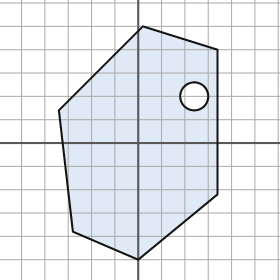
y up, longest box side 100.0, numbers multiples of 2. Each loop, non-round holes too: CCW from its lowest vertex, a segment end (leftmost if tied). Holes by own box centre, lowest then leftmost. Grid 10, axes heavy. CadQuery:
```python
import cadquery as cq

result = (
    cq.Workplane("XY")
    .moveTo(0.0, -50.0)
    .lineTo(34.0, -22.0)
    .lineTo(34.0, 40.0)
    .lineTo(2.0, 50.0)
    .lineTo(-34.0, 14.0)
    .lineTo(-28.0, -38.0)
    .close()
    .moveTo(24.0, 20.0)
    .circle(6.0)
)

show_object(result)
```